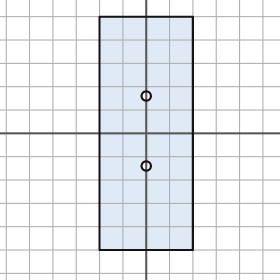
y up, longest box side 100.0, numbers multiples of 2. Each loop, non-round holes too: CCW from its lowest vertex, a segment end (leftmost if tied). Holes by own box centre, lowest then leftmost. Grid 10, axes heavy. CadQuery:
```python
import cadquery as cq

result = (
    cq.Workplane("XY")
    .moveTo(-20.0, -50.0)
    .lineTo(20.0, -50.0)
    .lineTo(20.0, 50.0)
    .lineTo(-20.0, 50.0)
    .close()
    .moveTo(0.0, -14.0)
    .circle(2.0)
    .moveTo(0.0, 16.0)
    .circle(2.0)
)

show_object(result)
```